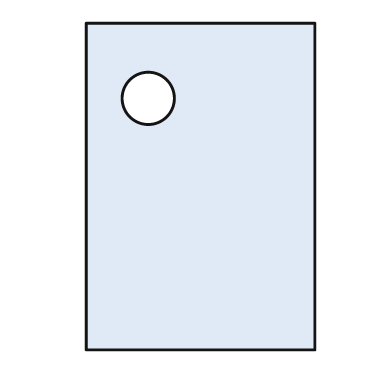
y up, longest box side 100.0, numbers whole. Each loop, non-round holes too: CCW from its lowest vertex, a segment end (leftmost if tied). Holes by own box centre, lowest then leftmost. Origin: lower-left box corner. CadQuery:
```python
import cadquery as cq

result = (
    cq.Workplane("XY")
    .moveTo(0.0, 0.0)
    .lineTo(70.0, 0.0)
    .lineTo(70.0, 100.0)
    .lineTo(0.0, 100.0)
    .close()
    .moveTo(19.0, 77.0)
    .circle(8.0)
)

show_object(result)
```